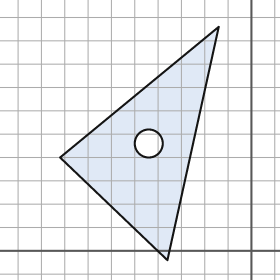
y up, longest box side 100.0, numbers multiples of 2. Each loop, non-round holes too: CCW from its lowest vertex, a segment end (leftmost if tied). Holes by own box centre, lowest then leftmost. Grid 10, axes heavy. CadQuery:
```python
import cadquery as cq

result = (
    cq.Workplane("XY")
    .moveTo(-36.0, -4.0)
    .lineTo(-14.0, 96.0)
    .lineTo(-82.0, 40.0)
    .close()
    .moveTo(-44.0, 46.0)
    .circle(6.0)
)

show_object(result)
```